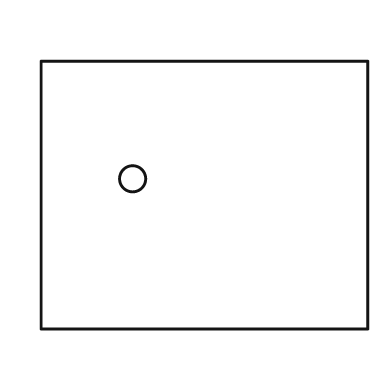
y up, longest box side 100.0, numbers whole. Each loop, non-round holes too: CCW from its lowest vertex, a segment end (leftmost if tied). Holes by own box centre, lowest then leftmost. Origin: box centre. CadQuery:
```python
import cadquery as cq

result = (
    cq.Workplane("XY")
    .moveTo(-50.0, -41.0)
    .lineTo(50.0, -41.0)
    .lineTo(50.0, 41.0)
    .lineTo(-50.0, 41.0)
    .close()
    .moveTo(-22.0, 5.0)
    .circle(4.0)
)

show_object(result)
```